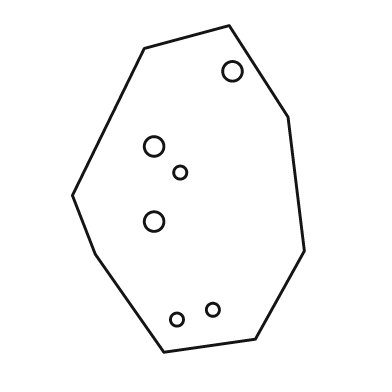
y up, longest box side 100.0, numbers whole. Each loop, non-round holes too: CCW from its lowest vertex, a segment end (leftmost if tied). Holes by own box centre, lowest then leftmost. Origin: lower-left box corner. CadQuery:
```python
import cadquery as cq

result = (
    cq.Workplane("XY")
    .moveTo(28.0, 0.0)
    .lineTo(56.0, 4.0)
    .lineTo(71.0, 31.0)
    .lineTo(66.0, 72.0)
    .lineTo(48.0, 100.0)
    .lineTo(22.0, 93.0)
    .lineTo(0.0, 48.0)
    .lineTo(7.0, 30.0)
    .close()
    .moveTo(32.0, 10.0)
    .circle(2.0)
    .moveTo(43.0, 13.0)
    .circle(2.0)
    .moveTo(25.0, 40.0)
    .circle(3.0)
    .moveTo(33.0, 55.0)
    .circle(2.0)
    .moveTo(25.0, 63.0)
    .circle(3.0)
    .moveTo(49.0, 86.0)
    .circle(3.0)
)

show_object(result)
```